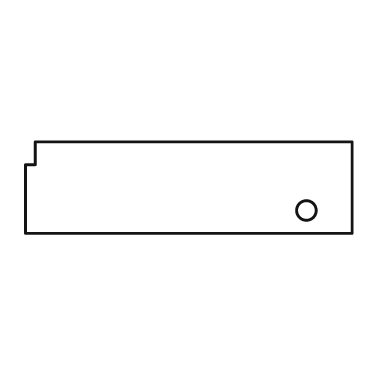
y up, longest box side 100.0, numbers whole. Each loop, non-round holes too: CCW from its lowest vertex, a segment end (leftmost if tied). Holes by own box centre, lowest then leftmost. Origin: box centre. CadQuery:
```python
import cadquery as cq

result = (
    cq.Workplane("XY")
    .moveTo(-50.0, -14.0)
    .lineTo(50.0, -14.0)
    .lineTo(50.0, 14.0)
    .lineTo(-47.0, 14.0)
    .lineTo(-47.0, 7.0)
    .lineTo(-50.0, 7.0)
    .close()
    .moveTo(36.0, -7.0)
    .circle(3.0)
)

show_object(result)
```